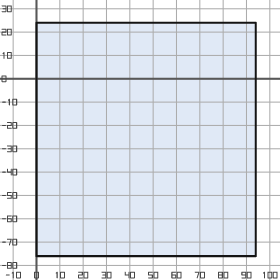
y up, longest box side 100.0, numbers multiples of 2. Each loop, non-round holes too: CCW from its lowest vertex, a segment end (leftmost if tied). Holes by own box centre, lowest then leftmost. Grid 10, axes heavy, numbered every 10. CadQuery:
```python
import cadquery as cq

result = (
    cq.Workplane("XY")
    .moveTo(0.0, -76.0)
    .lineTo(94.0, -76.0)
    .lineTo(94.0, 24.0)
    .lineTo(0.0, 24.0)
    .close()
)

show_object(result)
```